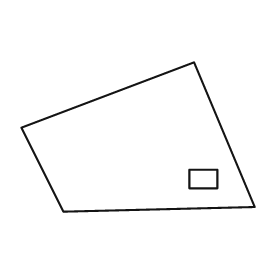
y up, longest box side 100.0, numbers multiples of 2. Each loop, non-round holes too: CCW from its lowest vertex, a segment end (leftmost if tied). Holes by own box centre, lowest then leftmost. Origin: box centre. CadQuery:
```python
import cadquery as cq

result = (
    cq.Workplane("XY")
    .moveTo(-32.0, -32.0)
    .lineTo(50.0, -30.0)
    .lineTo(24.0, 32.0)
    .lineTo(-50.0, 4.0)
    .close()
    .moveTo(22.0, -22.0)
    .lineTo(34.0, -22.0)
    .lineTo(34.0, -14.0)
    .lineTo(22.0, -14.0)
    .close()
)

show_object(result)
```